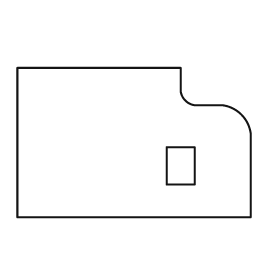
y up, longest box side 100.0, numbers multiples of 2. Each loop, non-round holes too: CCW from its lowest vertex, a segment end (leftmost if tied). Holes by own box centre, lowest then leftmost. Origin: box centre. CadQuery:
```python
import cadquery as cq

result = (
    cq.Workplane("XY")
    .moveTo(-50.0, -32.0)
    .lineTo(50.0, -32.0)
    .lineTo(50.0, 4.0)
    .threePointArc((46.0, 12.0), (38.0, 16.0))
    .lineTo(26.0, 16.0)
    .threePointArc((22.0, 18.0), (20.0, 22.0))
    .lineTo(20.0, 32.0)
    .lineTo(-50.0, 32.0)
    .close()
    .moveTo(14.0, -18.0)
    .lineTo(26.0, -18.0)
    .lineTo(26.0, -2.0)
    .lineTo(14.0, -2.0)
    .close()
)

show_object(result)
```